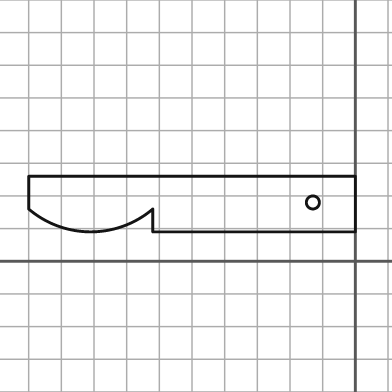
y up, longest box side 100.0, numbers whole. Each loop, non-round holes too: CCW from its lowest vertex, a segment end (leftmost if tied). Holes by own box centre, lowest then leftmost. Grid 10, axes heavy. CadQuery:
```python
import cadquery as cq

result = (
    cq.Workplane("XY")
    .moveTo(-62.0, 9.0)
    .lineTo(0.0, 9.0)
    .lineTo(0.0, 26.0)
    .lineTo(-100.0, 26.0)
    .lineTo(-100.0, 16.0)
    .threePointArc((-81.0, 9.0), (-62.0, 16.0))
    .close()
    .moveTo(-13.0, 18.0)
    .circle(2.0)
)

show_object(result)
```